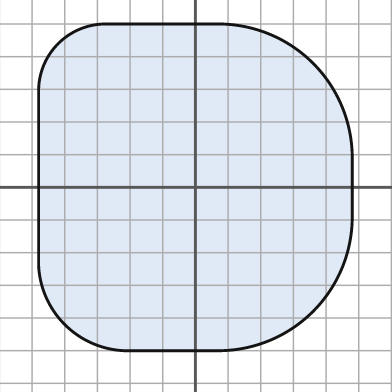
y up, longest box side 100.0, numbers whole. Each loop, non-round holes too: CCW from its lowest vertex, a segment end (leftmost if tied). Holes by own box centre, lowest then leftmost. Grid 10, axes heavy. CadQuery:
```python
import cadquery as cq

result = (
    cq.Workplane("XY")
    .moveTo(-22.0, -50.0)
    .lineTo(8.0, -50.0)
    .threePointArc((36.0, -38.0), (48.0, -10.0))
    .lineTo(48.0, 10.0)
    .threePointArc((36.0, 38.0), (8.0, 50.0))
    .lineTo(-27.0, 50.0)
    .threePointArc((-42.0, 44.0), (-48.0, 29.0))
    .lineTo(-48.0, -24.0)
    .threePointArc((-40.0, -42.0), (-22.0, -50.0))
    .close()
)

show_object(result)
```